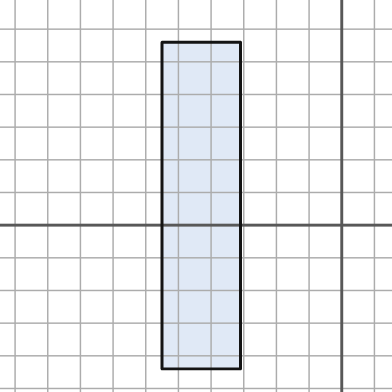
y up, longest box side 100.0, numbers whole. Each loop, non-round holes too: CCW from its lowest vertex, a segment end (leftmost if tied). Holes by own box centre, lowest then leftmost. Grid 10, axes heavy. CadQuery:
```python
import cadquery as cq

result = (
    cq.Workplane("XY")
    .moveTo(-55.0, -44.0)
    .lineTo(-31.0, -44.0)
    .lineTo(-31.0, 56.0)
    .lineTo(-55.0, 56.0)
    .close()
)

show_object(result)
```